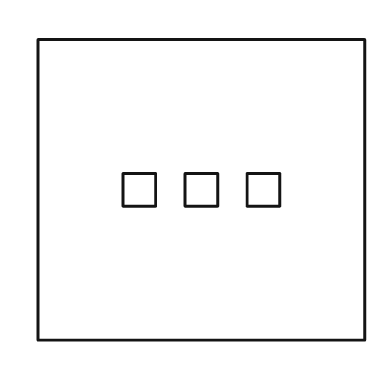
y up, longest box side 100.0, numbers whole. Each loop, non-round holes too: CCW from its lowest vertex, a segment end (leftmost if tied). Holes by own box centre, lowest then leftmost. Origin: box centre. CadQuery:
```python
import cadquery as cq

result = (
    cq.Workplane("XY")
    .moveTo(-50.0, -46.0)
    .lineTo(50.0, -46.0)
    .lineTo(50.0, 46.0)
    .lineTo(-50.0, 46.0)
    .close()
    .moveTo(-24.0, -5.0)
    .lineTo(-14.0, -5.0)
    .lineTo(-14.0, 5.0)
    .lineTo(-24.0, 5.0)
    .close()
    .moveTo(-5.0, -5.0)
    .lineTo(5.0, -5.0)
    .lineTo(5.0, 5.0)
    .lineTo(-5.0, 5.0)
    .close()
    .moveTo(14.0, -5.0)
    .lineTo(24.0, -5.0)
    .lineTo(24.0, 5.0)
    .lineTo(14.0, 5.0)
    .close()
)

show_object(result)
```